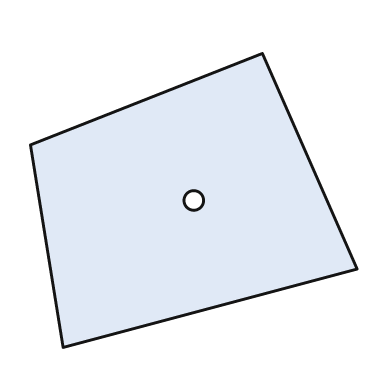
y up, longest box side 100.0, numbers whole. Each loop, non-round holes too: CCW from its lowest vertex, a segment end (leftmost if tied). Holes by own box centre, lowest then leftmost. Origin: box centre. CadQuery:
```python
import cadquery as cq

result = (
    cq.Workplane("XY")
    .moveTo(-40.0, -45.0)
    .lineTo(50.0, -21.0)
    .lineTo(21.0, 45.0)
    .lineTo(-50.0, 17.0)
    .close()
    .moveTo(0.0, 0.0)
    .circle(3.0)
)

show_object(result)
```